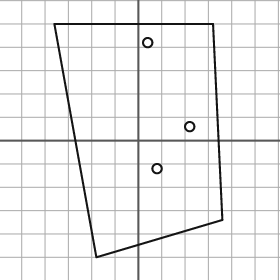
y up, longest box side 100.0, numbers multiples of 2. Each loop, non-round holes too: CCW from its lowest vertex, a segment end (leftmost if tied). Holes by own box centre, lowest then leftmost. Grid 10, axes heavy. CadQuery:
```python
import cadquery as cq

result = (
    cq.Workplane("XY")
    .moveTo(-18.0, -50.0)
    .lineTo(36.0, -34.0)
    .lineTo(32.0, 50.0)
    .lineTo(-36.0, 50.0)
    .close()
    .moveTo(8.0, -12.0)
    .circle(2.0)
    .moveTo(22.0, 6.0)
    .circle(2.0)
    .moveTo(4.0, 42.0)
    .circle(2.0)
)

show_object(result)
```